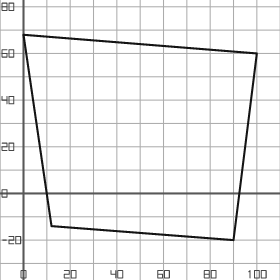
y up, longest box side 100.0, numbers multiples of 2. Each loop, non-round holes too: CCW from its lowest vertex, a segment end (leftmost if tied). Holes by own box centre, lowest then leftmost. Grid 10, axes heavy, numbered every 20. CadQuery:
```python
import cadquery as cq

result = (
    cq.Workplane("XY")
    .moveTo(90.0, -20.0)
    .lineTo(100.0, 60.0)
    .lineTo(0.0, 68.0)
    .lineTo(12.0, -14.0)
    .close()
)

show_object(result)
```